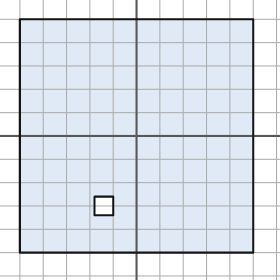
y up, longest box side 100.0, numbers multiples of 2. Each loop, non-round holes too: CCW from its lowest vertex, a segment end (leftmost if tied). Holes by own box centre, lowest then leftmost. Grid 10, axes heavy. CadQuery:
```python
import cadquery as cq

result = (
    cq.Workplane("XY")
    .moveTo(-50.0, -50.0)
    .lineTo(50.0, -50.0)
    .lineTo(50.0, 50.0)
    .lineTo(-50.0, 50.0)
    .close()
    .moveTo(-18.0, -34.0)
    .lineTo(-10.0, -34.0)
    .lineTo(-10.0, -26.0)
    .lineTo(-18.0, -26.0)
    .close()
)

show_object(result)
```